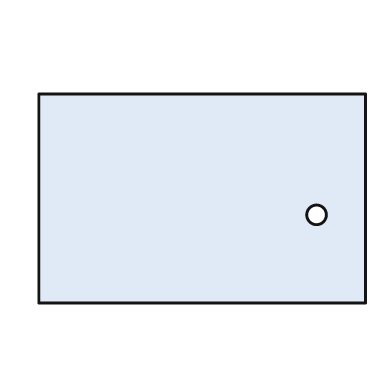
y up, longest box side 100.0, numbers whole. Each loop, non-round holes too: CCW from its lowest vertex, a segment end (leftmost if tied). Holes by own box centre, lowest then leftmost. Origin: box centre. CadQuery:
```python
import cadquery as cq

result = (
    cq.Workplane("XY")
    .moveTo(-50.0, -32.0)
    .lineTo(50.0, -32.0)
    .lineTo(50.0, 32.0)
    .lineTo(-50.0, 32.0)
    .close()
    .moveTo(35.0, -5.0)
    .circle(3.0)
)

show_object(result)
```